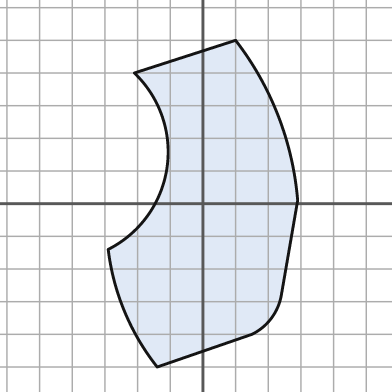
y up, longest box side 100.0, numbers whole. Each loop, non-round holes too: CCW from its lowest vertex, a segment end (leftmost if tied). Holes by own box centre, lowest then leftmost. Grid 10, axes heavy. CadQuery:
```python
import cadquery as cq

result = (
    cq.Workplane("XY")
    .moveTo(-14.0, -50.0)
    .lineTo(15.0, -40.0)
    .threePointArc((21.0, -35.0), (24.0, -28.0))
    .lineTo(29.0, 1.0)
    .threePointArc((23.0, 27.0), (10.0, 50.0))
    .lineTo(-21.0, 40.0)
    .threePointArc((-11.0, 11.0), (-29.0, -14.0))
    .threePointArc((-24.0, -33.0), (-14.0, -50.0))
    .close()
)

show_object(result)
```